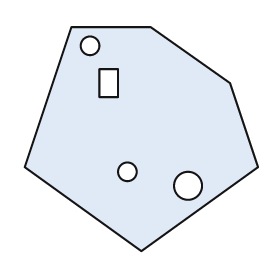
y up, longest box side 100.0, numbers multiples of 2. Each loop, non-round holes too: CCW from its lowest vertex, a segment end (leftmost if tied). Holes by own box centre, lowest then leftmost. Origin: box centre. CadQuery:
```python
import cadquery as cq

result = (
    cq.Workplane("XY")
    .moveTo(0.0, -48.0)
    .lineTo(50.0, -12.0)
    .lineTo(38.0, 24.0)
    .lineTo(4.0, 48.0)
    .lineTo(-30.0, 48.0)
    .lineTo(-50.0, -12.0)
    .close()
    .moveTo(20.0, -20.0)
    .circle(6.0)
    .moveTo(-6.0, -14.0)
    .circle(4.0)
    .moveTo(-18.0, 18.0)
    .lineTo(-10.0, 18.0)
    .lineTo(-10.0, 30.0)
    .lineTo(-18.0, 30.0)
    .close()
    .moveTo(-22.0, 40.0)
    .circle(4.0)
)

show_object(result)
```